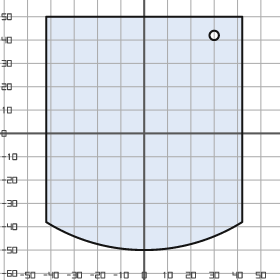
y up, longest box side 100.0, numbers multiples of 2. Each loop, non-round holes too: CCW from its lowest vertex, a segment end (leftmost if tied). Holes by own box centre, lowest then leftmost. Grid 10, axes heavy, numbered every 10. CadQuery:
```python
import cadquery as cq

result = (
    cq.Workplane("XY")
    .moveTo(-42.0, -38.0)
    .threePointArc((0.0, -50.0), (42.0, -38.0))
    .lineTo(42.0, 50.0)
    .lineTo(-42.0, 50.0)
    .close()
    .moveTo(30.0, 42.0)
    .circle(2.0)
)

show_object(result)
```